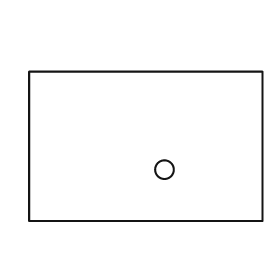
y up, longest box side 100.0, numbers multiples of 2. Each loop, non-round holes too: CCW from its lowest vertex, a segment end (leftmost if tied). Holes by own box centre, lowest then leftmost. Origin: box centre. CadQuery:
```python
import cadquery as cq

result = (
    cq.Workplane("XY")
    .moveTo(-50.0, -32.0)
    .lineTo(50.0, -32.0)
    .lineTo(50.0, 32.0)
    .lineTo(-50.0, 32.0)
    .close()
    .moveTo(8.0, -10.0)
    .circle(4.0)
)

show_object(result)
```